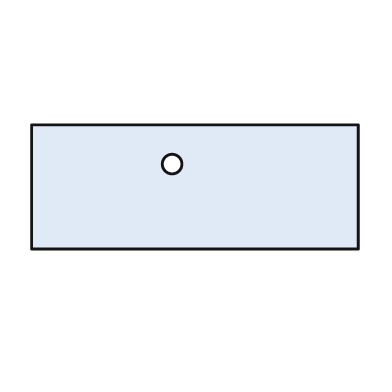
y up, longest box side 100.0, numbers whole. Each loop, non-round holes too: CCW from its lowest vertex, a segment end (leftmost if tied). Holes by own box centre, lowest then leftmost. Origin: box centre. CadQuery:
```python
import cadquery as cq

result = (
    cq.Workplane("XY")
    .moveTo(-50.0, -19.0)
    .lineTo(50.0, -19.0)
    .lineTo(50.0, 19.0)
    .lineTo(-50.0, 19.0)
    .close()
    .moveTo(-7.0, 7.0)
    .circle(3.0)
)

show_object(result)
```